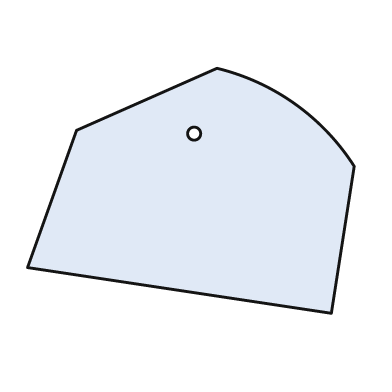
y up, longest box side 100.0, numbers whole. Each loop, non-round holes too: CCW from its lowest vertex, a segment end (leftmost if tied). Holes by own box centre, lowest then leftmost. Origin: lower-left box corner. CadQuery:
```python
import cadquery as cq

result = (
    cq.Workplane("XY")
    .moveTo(93.0, 0.0)
    .lineTo(100.0, 45.0)
    .threePointArc((82.0, 64.0), (58.0, 75.0))
    .lineTo(15.0, 56.0)
    .lineTo(0.0, 14.0)
    .close()
    .moveTo(51.0, 55.0)
    .circle(2.0)
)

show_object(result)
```